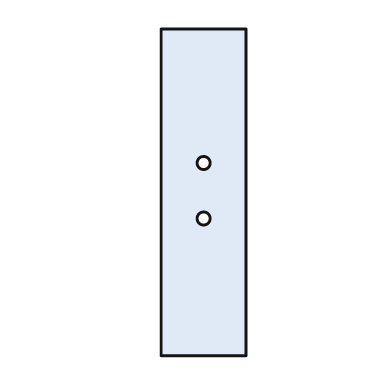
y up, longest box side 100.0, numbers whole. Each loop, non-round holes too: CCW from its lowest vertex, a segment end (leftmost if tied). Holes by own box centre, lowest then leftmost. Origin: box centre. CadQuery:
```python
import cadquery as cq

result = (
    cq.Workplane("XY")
    .moveTo(-13.0, -50.0)
    .lineTo(13.0, -50.0)
    .lineTo(13.0, 50.0)
    .lineTo(-13.0, 50.0)
    .close()
    .moveTo(0.0, -8.0)
    .circle(2.0)
    .moveTo(0.0, 9.0)
    .circle(2.0)
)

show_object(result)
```